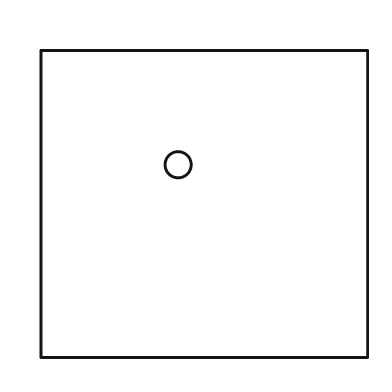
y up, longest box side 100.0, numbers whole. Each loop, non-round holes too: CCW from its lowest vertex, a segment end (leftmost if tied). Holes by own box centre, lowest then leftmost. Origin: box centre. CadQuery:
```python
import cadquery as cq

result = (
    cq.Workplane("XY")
    .moveTo(-50.0, -47.0)
    .lineTo(50.0, -47.0)
    .lineTo(50.0, 47.0)
    .lineTo(-50.0, 47.0)
    .close()
    .moveTo(-8.0, 12.0)
    .circle(4.0)
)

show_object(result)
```